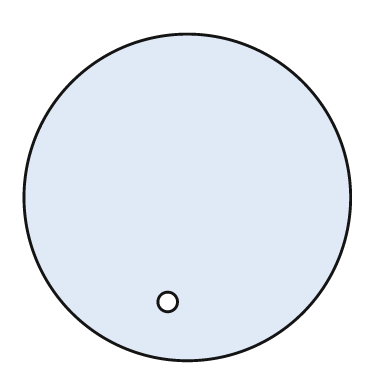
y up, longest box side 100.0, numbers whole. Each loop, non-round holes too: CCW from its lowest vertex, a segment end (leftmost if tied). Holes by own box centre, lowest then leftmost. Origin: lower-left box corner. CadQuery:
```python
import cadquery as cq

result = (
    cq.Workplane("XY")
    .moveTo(50.0, 50.0)
    .circle(50.0)
    .moveTo(44.0, 18.0)
    .circle(3.0)
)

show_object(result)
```